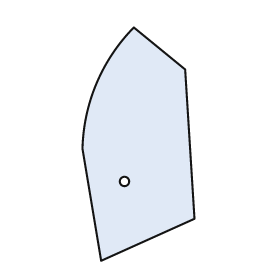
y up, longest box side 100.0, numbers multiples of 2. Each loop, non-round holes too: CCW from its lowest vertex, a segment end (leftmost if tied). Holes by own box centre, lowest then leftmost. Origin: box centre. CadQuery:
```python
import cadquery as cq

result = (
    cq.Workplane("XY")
    .moveTo(-16.0, -50.0)
    .lineTo(24.0, -32.0)
    .lineTo(20.0, 32.0)
    .lineTo(-2.0, 50.0)
    .threePointArc((-18.0, 26.0), (-24.0, -2.0))
    .close()
    .moveTo(-6.0, -16.0)
    .circle(2.0)
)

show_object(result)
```